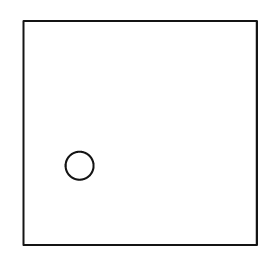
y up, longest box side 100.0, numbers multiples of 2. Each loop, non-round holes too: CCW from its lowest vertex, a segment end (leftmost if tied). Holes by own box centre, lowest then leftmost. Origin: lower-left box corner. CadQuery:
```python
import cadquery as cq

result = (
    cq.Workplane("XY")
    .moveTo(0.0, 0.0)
    .lineTo(100.0, 0.0)
    .lineTo(100.0, 96.0)
    .lineTo(0.0, 96.0)
    .close()
    .moveTo(24.0, 34.0)
    .circle(6.0)
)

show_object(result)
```